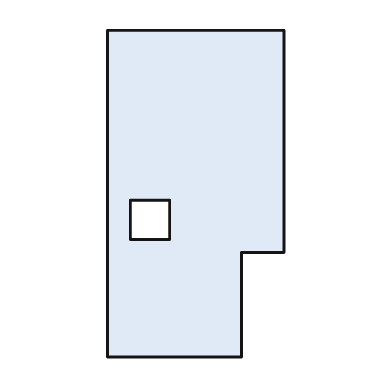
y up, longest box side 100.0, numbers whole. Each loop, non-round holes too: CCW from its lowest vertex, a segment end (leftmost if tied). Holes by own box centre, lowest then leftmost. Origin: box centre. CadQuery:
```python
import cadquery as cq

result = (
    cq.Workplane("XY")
    .moveTo(-27.0, -50.0)
    .lineTo(14.0, -50.0)
    .lineTo(14.0, -18.0)
    .lineTo(27.0, -18.0)
    .lineTo(27.0, 50.0)
    .lineTo(-27.0, 50.0)
    .close()
    .moveTo(-20.0, -14.0)
    .lineTo(-8.0, -14.0)
    .lineTo(-8.0, -2.0)
    .lineTo(-20.0, -2.0)
    .close()
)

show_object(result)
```